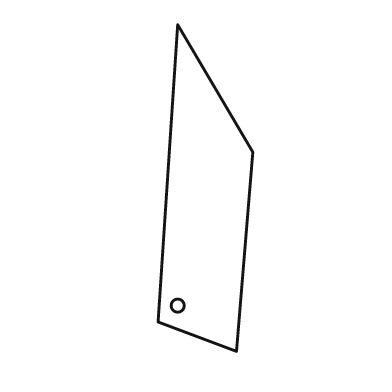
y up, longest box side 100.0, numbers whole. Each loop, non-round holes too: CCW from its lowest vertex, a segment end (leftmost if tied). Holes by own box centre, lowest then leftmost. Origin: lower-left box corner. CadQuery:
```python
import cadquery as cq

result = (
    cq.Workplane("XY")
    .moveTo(24.0, 0.0)
    .lineTo(29.0, 61.0)
    .lineTo(6.0, 100.0)
    .lineTo(0.0, 9.0)
    .close()
    .moveTo(6.0, 14.0)
    .circle(2.0)
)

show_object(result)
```